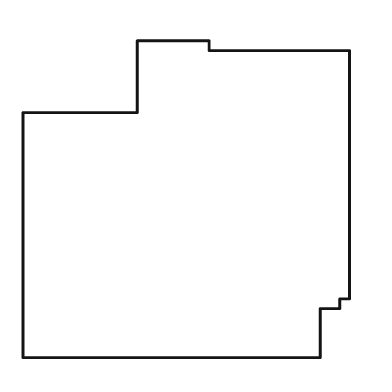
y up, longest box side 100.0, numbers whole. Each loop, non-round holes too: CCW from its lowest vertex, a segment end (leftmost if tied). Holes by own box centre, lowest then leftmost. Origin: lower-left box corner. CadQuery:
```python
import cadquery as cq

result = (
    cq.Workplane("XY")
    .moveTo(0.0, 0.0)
    .lineTo(91.0, 0.0)
    .lineTo(91.0, 15.0)
    .lineTo(97.0, 15.0)
    .lineTo(97.0, 18.0)
    .lineTo(100.0, 18.0)
    .lineTo(100.0, 94.0)
    .lineTo(57.0, 94.0)
    .lineTo(57.0, 97.0)
    .lineTo(35.0, 97.0)
    .lineTo(35.0, 75.0)
    .lineTo(0.0, 75.0)
    .close()
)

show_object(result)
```